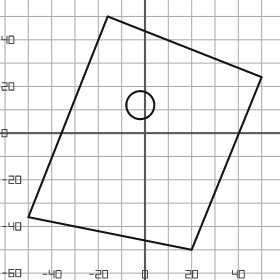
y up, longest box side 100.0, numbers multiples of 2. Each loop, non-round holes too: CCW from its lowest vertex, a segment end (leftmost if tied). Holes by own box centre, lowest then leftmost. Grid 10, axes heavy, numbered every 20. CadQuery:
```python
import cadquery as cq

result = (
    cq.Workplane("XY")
    .moveTo(20.0, -50.0)
    .lineTo(50.0, 24.0)
    .lineTo(-16.0, 50.0)
    .lineTo(-50.0, -36.0)
    .close()
    .moveTo(-2.0, 12.0)
    .circle(6.0)
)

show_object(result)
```